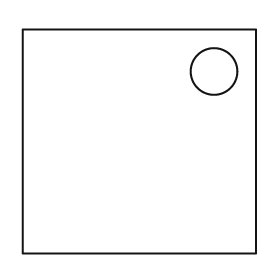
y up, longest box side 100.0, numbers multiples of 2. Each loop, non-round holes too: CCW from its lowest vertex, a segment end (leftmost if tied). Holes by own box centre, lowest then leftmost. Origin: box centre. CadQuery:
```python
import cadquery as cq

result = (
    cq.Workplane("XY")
    .moveTo(-50.0, -48.0)
    .lineTo(50.0, -48.0)
    .lineTo(50.0, 48.0)
    .lineTo(-50.0, 48.0)
    .close()
    .moveTo(32.0, 30.0)
    .circle(10.0)
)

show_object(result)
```